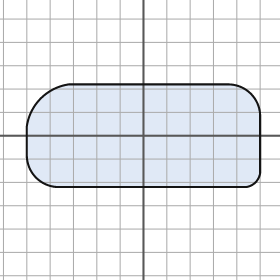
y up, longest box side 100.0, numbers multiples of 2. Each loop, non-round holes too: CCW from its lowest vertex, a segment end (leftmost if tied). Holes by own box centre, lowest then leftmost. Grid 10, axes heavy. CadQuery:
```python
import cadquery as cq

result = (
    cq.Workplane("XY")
    .moveTo(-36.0, -22.0)
    .lineTo(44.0, -22.0)
    .threePointArc((48.0, -20.0), (50.0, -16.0))
    .lineTo(50.0, 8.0)
    .threePointArc((46.0, 18.0), (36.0, 22.0))
    .lineTo(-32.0, 22.0)
    .threePointArc((-44.0, 16.0), (-50.0, 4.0))
    .lineTo(-50.0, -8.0)
    .threePointArc((-46.0, -18.0), (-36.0, -22.0))
    .close()
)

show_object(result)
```